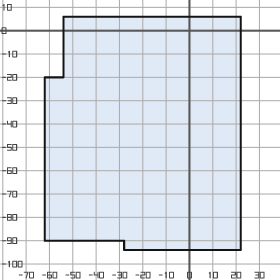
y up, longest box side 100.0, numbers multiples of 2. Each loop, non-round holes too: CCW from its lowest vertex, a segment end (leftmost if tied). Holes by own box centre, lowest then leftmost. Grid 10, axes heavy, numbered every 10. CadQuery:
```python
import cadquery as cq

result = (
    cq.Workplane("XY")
    .moveTo(-28.0, -94.0)
    .lineTo(22.0, -94.0)
    .lineTo(22.0, 6.0)
    .lineTo(-54.0, 6.0)
    .lineTo(-54.0, -20.0)
    .lineTo(-62.0, -20.0)
    .lineTo(-62.0, -90.0)
    .lineTo(-28.0, -90.0)
    .close()
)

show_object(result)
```